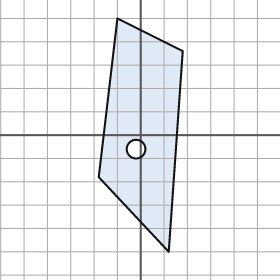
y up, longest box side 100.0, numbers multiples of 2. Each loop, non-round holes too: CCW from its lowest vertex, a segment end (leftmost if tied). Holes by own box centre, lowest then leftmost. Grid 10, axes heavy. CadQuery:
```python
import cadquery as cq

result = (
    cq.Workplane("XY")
    .moveTo(12.0, -50.0)
    .lineTo(18.0, 36.0)
    .lineTo(-10.0, 50.0)
    .lineTo(-18.0, -18.0)
    .close()
    .moveTo(-2.0, -6.0)
    .circle(4.0)
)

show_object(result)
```